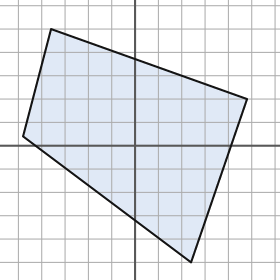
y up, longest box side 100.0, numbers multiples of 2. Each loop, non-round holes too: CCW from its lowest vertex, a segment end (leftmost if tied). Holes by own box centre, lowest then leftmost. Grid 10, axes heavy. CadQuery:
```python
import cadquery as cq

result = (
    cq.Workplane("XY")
    .moveTo(24.0, -50.0)
    .lineTo(48.0, 20.0)
    .lineTo(-36.0, 50.0)
    .lineTo(-48.0, 4.0)
    .close()
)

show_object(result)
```